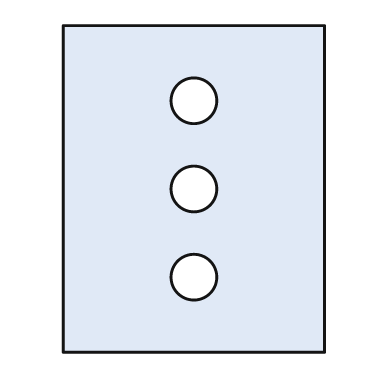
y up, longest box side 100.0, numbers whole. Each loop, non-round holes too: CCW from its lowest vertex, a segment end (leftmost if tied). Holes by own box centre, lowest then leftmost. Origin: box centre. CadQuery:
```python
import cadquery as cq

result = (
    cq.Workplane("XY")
    .moveTo(-40.0, -50.0)
    .lineTo(40.0, -50.0)
    .lineTo(40.0, 50.0)
    .lineTo(-40.0, 50.0)
    .close()
    .moveTo(0.0, -27.0)
    .circle(7.0)
    .moveTo(0.0, 0.0)
    .circle(7.0)
    .moveTo(0.0, 27.0)
    .circle(7.0)
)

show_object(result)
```